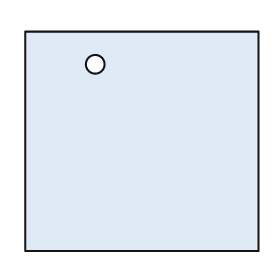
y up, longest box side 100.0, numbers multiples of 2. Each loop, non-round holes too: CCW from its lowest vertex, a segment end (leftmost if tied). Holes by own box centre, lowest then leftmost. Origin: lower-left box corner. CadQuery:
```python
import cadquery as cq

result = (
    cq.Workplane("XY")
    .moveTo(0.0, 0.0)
    .lineTo(100.0, 0.0)
    .lineTo(100.0, 94.0)
    .lineTo(0.0, 94.0)
    .close()
    .moveTo(30.0, 80.0)
    .circle(4.0)
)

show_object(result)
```